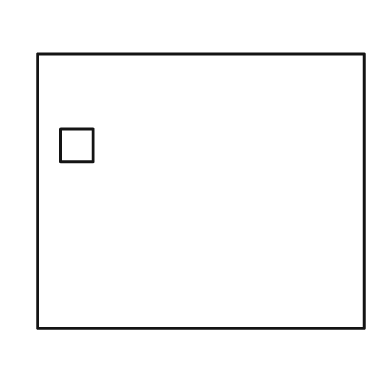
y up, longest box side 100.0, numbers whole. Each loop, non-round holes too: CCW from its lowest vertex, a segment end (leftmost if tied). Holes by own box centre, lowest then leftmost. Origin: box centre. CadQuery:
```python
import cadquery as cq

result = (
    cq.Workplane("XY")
    .moveTo(-50.0, -42.0)
    .lineTo(50.0, -42.0)
    .lineTo(50.0, 42.0)
    .lineTo(-50.0, 42.0)
    .close()
    .moveTo(-43.0, 9.0)
    .lineTo(-33.0, 9.0)
    .lineTo(-33.0, 19.0)
    .lineTo(-43.0, 19.0)
    .close()
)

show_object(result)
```